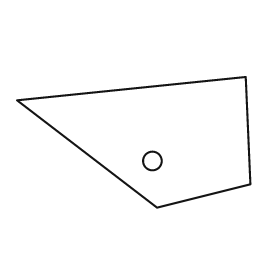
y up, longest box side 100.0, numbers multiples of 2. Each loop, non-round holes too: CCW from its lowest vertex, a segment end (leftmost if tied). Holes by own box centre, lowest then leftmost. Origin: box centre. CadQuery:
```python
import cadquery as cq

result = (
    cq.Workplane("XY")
    .moveTo(10.0, -28.0)
    .lineTo(50.0, -18.0)
    .lineTo(48.0, 28.0)
    .lineTo(-50.0, 18.0)
    .close()
    .moveTo(8.0, -8.0)
    .circle(4.0)
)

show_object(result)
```